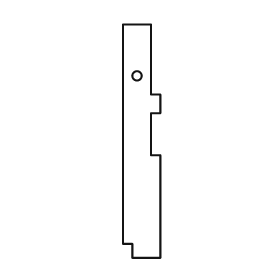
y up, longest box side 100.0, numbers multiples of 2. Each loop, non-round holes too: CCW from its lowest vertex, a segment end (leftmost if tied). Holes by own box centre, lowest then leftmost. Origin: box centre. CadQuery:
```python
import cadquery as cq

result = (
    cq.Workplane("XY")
    .moveTo(-4.0, -50.0)
    .lineTo(8.0, -50.0)
    .lineTo(8.0, -6.0)
    .lineTo(4.0, -6.0)
    .lineTo(4.0, 12.0)
    .lineTo(8.0, 12.0)
    .lineTo(8.0, 20.0)
    .lineTo(4.0, 20.0)
    .lineTo(4.0, 50.0)
    .lineTo(-8.0, 50.0)
    .lineTo(-8.0, -44.0)
    .lineTo(-4.0, -44.0)
    .close()
    .moveTo(-2.0, 28.0)
    .circle(2.0)
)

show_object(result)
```